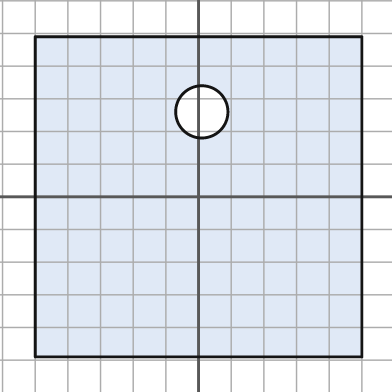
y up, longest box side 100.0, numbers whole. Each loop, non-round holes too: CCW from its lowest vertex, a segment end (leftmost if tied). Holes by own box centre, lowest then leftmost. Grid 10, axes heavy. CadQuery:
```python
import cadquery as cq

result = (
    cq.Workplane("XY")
    .moveTo(-50.0, -49.0)
    .lineTo(50.0, -49.0)
    .lineTo(50.0, 49.0)
    .lineTo(-50.0, 49.0)
    .close()
    .moveTo(1.0, 26.0)
    .circle(8.0)
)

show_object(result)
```